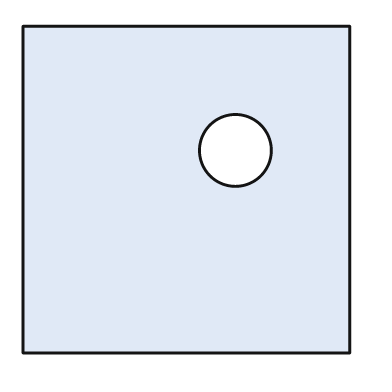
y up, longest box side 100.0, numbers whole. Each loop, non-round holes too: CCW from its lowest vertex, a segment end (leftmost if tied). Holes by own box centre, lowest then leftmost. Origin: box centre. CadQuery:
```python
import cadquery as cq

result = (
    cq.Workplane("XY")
    .moveTo(-50.0, -50.0)
    .lineTo(50.0, -50.0)
    .lineTo(50.0, 50.0)
    .lineTo(-50.0, 50.0)
    .close()
    .moveTo(15.0, 12.0)
    .circle(11.0)
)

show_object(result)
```